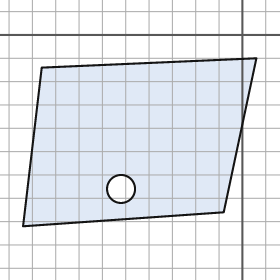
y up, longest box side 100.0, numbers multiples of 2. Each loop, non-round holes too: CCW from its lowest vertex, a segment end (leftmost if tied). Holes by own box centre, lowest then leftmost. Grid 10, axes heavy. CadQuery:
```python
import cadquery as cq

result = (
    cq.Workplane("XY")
    .moveTo(-94.0, -82.0)
    .lineTo(-8.0, -76.0)
    .lineTo(6.0, -10.0)
    .lineTo(-86.0, -14.0)
    .close()
    .moveTo(-52.0, -66.0)
    .circle(6.0)
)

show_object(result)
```